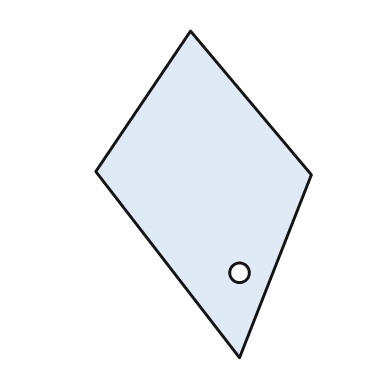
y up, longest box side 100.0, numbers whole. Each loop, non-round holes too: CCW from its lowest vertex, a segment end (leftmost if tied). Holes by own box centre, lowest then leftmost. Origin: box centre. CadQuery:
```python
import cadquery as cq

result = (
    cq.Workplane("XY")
    .moveTo(11.0, -50.0)
    .lineTo(33.0, 6.0)
    .lineTo(-4.0, 50.0)
    .lineTo(-33.0, 7.0)
    .close()
    .moveTo(11.0, -24.0)
    .circle(3.0)
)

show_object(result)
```